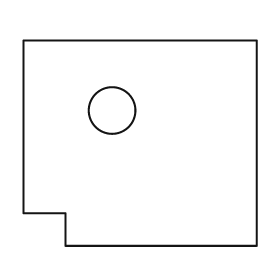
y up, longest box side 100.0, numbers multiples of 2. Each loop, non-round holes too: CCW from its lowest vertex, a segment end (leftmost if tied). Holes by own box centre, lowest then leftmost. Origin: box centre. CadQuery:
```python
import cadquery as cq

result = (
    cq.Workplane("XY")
    .moveTo(-32.0, -44.0)
    .lineTo(50.0, -44.0)
    .lineTo(50.0, 44.0)
    .lineTo(-50.0, 44.0)
    .lineTo(-50.0, -30.0)
    .lineTo(-32.0, -30.0)
    .close()
    .moveTo(-12.0, 14.0)
    .circle(10.0)
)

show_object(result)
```